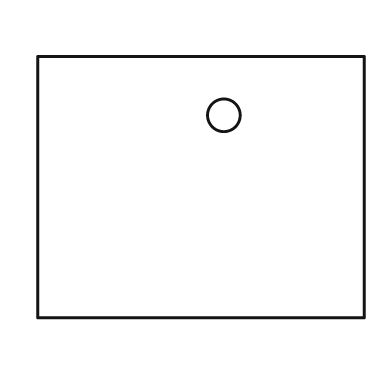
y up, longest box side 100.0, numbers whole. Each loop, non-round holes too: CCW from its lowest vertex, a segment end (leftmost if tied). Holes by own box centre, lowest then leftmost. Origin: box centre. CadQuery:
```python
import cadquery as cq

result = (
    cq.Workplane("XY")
    .moveTo(-50.0, -40.0)
    .lineTo(50.0, -40.0)
    .lineTo(50.0, 40.0)
    .lineTo(-50.0, 40.0)
    .close()
    .moveTo(7.0, 22.0)
    .circle(5.0)
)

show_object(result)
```